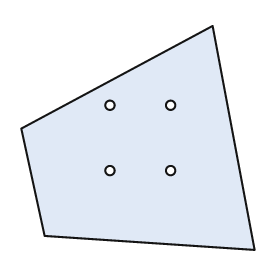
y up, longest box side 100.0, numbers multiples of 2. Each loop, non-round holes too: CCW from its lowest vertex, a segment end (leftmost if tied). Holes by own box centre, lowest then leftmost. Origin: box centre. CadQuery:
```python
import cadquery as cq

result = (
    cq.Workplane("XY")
    .moveTo(50.0, -48.0)
    .lineTo(32.0, 48.0)
    .lineTo(-50.0, 4.0)
    .lineTo(-40.0, -42.0)
    .close()
    .moveTo(-12.0, -14.0)
    .circle(2.0)
    .moveTo(14.0, -14.0)
    .circle(2.0)
    .moveTo(-12.0, 14.0)
    .circle(2.0)
    .moveTo(14.0, 14.0)
    .circle(2.0)
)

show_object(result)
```